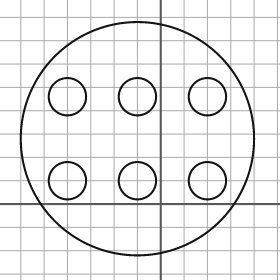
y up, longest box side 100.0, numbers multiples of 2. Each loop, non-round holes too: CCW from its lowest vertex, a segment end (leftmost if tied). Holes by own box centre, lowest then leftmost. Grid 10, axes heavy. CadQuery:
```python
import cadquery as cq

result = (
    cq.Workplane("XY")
    .moveTo(-10.0, 28.0)
    .circle(50.0)
    .moveTo(-40.0, 10.0)
    .circle(8.0)
    .moveTo(-10.0, 10.0)
    .circle(8.0)
    .moveTo(20.0, 10.0)
    .circle(8.0)
    .moveTo(-40.0, 46.0)
    .circle(8.0)
    .moveTo(-10.0, 46.0)
    .circle(8.0)
    .moveTo(20.0, 46.0)
    .circle(8.0)
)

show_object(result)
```